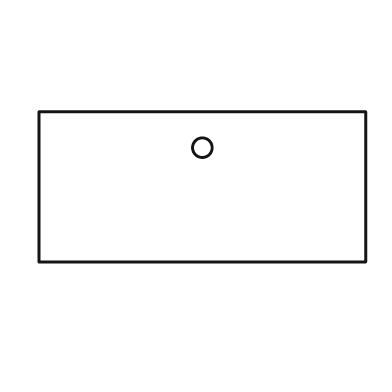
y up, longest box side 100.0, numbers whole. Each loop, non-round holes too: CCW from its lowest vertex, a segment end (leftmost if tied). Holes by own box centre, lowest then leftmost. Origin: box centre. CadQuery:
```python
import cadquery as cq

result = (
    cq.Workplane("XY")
    .moveTo(-50.0, -23.0)
    .lineTo(50.0, -23.0)
    .lineTo(50.0, 23.0)
    .lineTo(-50.0, 23.0)
    .close()
    .moveTo(0.0, 12.0)
    .circle(3.0)
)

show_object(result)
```